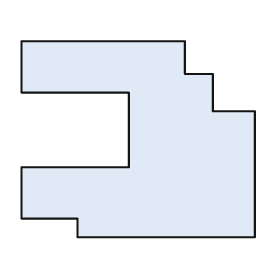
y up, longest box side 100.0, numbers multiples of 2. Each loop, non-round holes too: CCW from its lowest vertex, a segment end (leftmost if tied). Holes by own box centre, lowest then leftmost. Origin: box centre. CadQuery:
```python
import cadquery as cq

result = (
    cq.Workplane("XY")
    .moveTo(-26.0, -42.0)
    .lineTo(50.0, -42.0)
    .lineTo(50.0, 12.0)
    .lineTo(32.0, 12.0)
    .lineTo(32.0, 28.0)
    .lineTo(20.0, 28.0)
    .lineTo(20.0, 42.0)
    .lineTo(-50.0, 42.0)
    .lineTo(-50.0, 20.0)
    .lineTo(-4.0, 20.0)
    .lineTo(-4.0, -12.0)
    .lineTo(-50.0, -12.0)
    .lineTo(-50.0, -34.0)
    .lineTo(-26.0, -34.0)
    .close()
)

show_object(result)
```